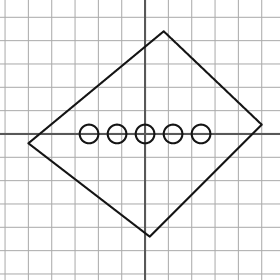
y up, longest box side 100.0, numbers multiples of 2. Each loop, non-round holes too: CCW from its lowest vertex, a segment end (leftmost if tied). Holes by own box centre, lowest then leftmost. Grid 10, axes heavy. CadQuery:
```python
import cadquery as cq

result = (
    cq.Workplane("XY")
    .moveTo(2.0, -44.0)
    .lineTo(50.0, 4.0)
    .lineTo(8.0, 44.0)
    .lineTo(-50.0, -4.0)
    .close()
    .moveTo(-24.0, 0.0)
    .circle(4.0)
    .moveTo(-12.0, 0.0)
    .circle(4.0)
    .moveTo(0.0, 0.0)
    .circle(4.0)
    .moveTo(12.0, 0.0)
    .circle(4.0)
    .moveTo(24.0, 0.0)
    .circle(4.0)
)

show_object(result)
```